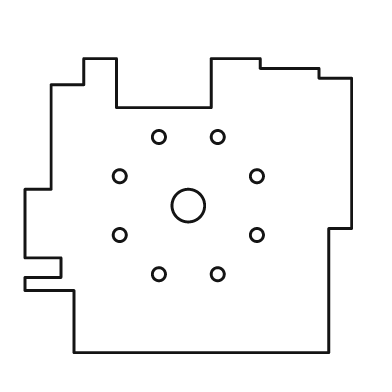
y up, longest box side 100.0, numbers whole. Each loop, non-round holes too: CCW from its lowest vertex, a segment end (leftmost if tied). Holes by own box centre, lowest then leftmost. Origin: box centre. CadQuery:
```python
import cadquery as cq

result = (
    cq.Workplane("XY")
    .moveTo(-35.0, -45.0)
    .lineTo(43.0, -45.0)
    .lineTo(43.0, -7.0)
    .lineTo(50.0, -7.0)
    .lineTo(50.0, 39.0)
    .lineTo(40.0, 39.0)
    .lineTo(40.0, 42.0)
    .lineTo(22.0, 42.0)
    .lineTo(22.0, 45.0)
    .lineTo(7.0, 45.0)
    .lineTo(7.0, 30.0)
    .lineTo(-22.0, 30.0)
    .lineTo(-22.0, 45.0)
    .lineTo(-32.0, 45.0)
    .lineTo(-32.0, 37.0)
    .lineTo(-42.0, 37.0)
    .lineTo(-42.0, 5.0)
    .lineTo(-50.0, 5.0)
    .lineTo(-50.0, -16.0)
    .lineTo(-39.0, -16.0)
    .lineTo(-39.0, -22.0)
    .lineTo(-50.0, -22.0)
    .lineTo(-50.0, -26.0)
    .lineTo(-35.0, -26.0)
    .close()
    .moveTo(-9.0, -21.0)
    .circle(2.0)
    .moveTo(9.0, -21.0)
    .circle(2.0)
    .moveTo(-21.0, -9.0)
    .circle(2.0)
    .moveTo(21.0, -9.0)
    .circle(2.0)
    .moveTo(0.0, 0.0)
    .circle(5.0)
    .moveTo(-21.0, 9.0)
    .circle(2.0)
    .moveTo(21.0, 9.0)
    .circle(2.0)
    .moveTo(-9.0, 21.0)
    .circle(2.0)
    .moveTo(9.0, 21.0)
    .circle(2.0)
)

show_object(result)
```